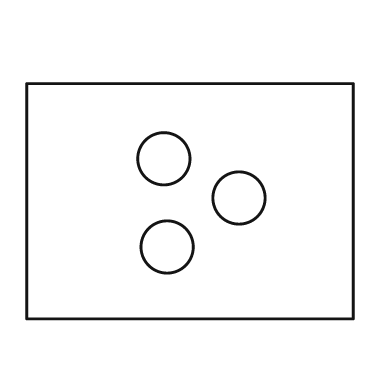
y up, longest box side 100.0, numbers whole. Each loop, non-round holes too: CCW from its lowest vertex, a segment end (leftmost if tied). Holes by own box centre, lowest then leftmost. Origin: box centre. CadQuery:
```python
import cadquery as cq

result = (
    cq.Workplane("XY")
    .moveTo(-50.0, -36.0)
    .lineTo(50.0, -36.0)
    .lineTo(50.0, 36.0)
    .lineTo(-50.0, 36.0)
    .close()
    .moveTo(-7.0, -14.0)
    .circle(8.0)
    .moveTo(15.0, 1.0)
    .circle(8.0)
    .moveTo(-8.0, 13.0)
    .circle(8.0)
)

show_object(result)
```